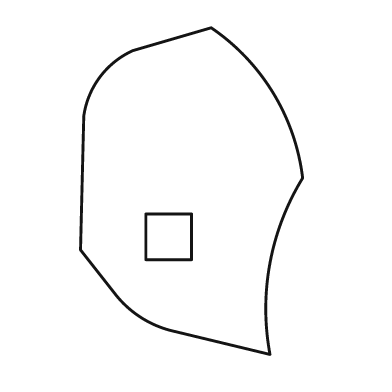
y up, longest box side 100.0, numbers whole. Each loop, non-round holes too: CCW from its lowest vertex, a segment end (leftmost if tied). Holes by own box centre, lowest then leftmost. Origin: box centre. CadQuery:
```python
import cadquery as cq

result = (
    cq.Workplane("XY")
    .moveTo(24.0, -50.0)
    .threePointArc((24.0, -22.0), (34.0, 4.0))
    .threePointArc((25.0, 30.0), (6.0, 50.0))
    .lineTo(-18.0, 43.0)
    .threePointArc((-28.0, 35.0), (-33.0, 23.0))
    .lineTo(-34.0, -18.0)
    .lineTo(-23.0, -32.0)
    .threePointArc((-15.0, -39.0), (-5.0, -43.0))
    .close()
    .moveTo(-14.0, -21.0)
    .lineTo(0.0, -21.0)
    .lineTo(0.0, -7.0)
    .lineTo(-14.0, -7.0)
    .close()
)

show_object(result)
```